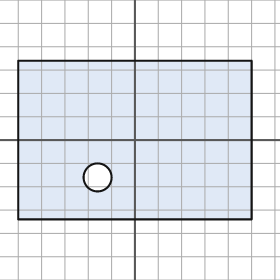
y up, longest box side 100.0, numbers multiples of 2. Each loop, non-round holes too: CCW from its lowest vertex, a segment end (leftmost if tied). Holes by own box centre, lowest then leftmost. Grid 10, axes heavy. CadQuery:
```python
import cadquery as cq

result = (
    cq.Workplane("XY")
    .moveTo(-50.0, -34.0)
    .lineTo(50.0, -34.0)
    .lineTo(50.0, 34.0)
    .lineTo(-50.0, 34.0)
    .close()
    .moveTo(-16.0, -16.0)
    .circle(6.0)
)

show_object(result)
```